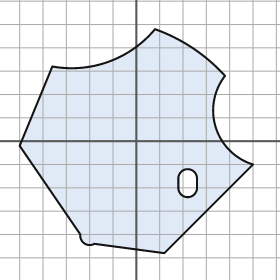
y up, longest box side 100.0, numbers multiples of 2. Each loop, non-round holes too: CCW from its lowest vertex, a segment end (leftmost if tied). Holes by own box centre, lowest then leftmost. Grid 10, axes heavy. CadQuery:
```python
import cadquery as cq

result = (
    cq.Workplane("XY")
    .moveTo(12.0, -48.0)
    .lineTo(50.0, -10.0)
    .threePointArc((34.0, 6.0), (38.0, 28.0))
    .threePointArc((24.0, 40.0), (8.0, 48.0))
    .threePointArc((-12.0, 34.0), (-36.0, 32.0))
    .lineTo(-50.0, -2.0)
    .lineTo(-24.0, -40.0)
    .threePointArc((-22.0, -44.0), (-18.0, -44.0))
    .close()
    .moveTo(18.0, -20.0)
    .threePointArc((22.0, -24.0), (26.0, -20.0))
    .lineTo(26.0, -16.0)
    .threePointArc((22.0, -12.0), (18.0, -16.0))
    .close()
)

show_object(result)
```